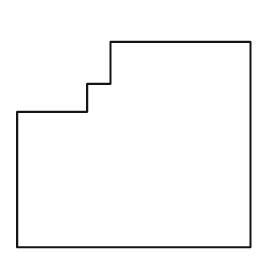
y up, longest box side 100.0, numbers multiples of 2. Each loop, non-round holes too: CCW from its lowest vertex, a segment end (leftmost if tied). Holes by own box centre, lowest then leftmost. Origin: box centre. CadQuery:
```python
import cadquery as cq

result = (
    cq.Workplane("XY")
    .moveTo(-50.0, -44.0)
    .lineTo(50.0, -44.0)
    .lineTo(50.0, 44.0)
    .lineTo(-10.0, 44.0)
    .lineTo(-10.0, 26.0)
    .lineTo(-20.0, 26.0)
    .lineTo(-20.0, 14.0)
    .lineTo(-50.0, 14.0)
    .close()
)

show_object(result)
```